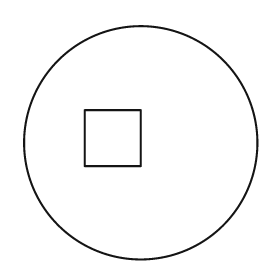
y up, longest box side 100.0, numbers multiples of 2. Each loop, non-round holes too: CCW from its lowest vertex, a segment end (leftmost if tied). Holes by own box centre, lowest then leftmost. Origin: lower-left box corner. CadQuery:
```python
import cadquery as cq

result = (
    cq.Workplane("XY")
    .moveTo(50.0, 50.0)
    .circle(50.0)
    .moveTo(26.0, 40.0)
    .lineTo(50.0, 40.0)
    .lineTo(50.0, 64.0)
    .lineTo(26.0, 64.0)
    .close()
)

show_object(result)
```